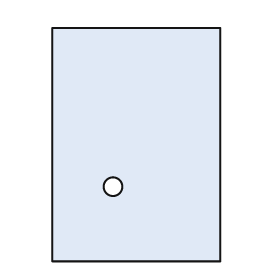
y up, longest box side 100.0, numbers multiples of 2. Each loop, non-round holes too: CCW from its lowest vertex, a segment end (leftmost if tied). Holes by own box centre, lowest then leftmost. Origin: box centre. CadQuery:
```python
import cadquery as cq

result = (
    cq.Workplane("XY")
    .moveTo(-36.0, -50.0)
    .lineTo(36.0, -50.0)
    .lineTo(36.0, 50.0)
    .lineTo(-36.0, 50.0)
    .close()
    .moveTo(-10.0, -18.0)
    .circle(4.0)
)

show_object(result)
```